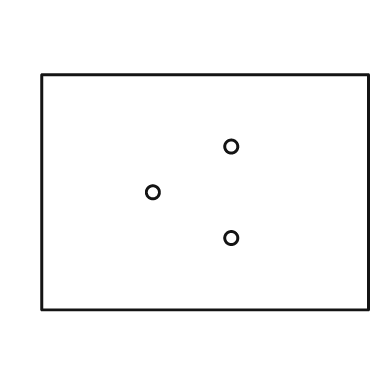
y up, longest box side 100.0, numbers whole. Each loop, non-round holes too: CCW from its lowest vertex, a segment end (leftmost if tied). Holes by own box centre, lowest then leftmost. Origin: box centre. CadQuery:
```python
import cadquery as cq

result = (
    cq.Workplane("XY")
    .moveTo(-50.0, -36.0)
    .lineTo(50.0, -36.0)
    .lineTo(50.0, 36.0)
    .lineTo(-50.0, 36.0)
    .close()
    .moveTo(8.0, -14.0)
    .circle(2.0)
    .moveTo(-16.0, 0.0)
    .circle(2.0)
    .moveTo(8.0, 14.0)
    .circle(2.0)
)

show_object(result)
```